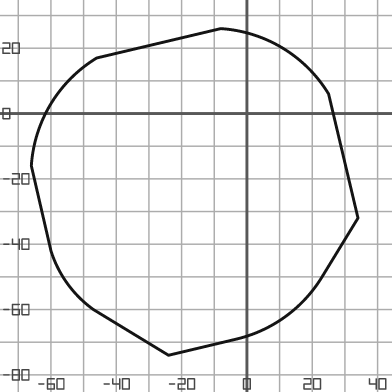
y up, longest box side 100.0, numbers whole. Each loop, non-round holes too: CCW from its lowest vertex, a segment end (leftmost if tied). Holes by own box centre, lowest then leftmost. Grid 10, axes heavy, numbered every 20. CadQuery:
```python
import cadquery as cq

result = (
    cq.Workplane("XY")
    .moveTo(-24.0, -74.0)
    .lineTo(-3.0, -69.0)
    .threePointArc((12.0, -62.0), (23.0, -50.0))
    .lineTo(34.0, -32.0)
    .lineTo(25.0, 6.0)
    .threePointArc((11.0, 20.0), (-8.0, 26.0))
    .lineTo(-46.0, 17.0)
    .threePointArc((-60.0, 3.0), (-66.0, -16.0))
    .lineTo(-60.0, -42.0)
    .threePointArc((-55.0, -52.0), (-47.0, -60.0))
    .close()
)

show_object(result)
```